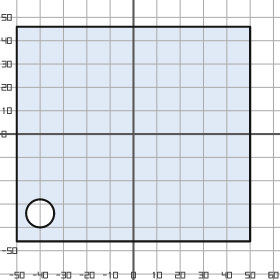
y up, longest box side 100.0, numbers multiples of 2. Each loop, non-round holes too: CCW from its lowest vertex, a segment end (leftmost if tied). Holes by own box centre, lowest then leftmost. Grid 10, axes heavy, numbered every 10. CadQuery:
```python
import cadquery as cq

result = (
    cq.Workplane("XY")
    .moveTo(-50.0, -46.0)
    .lineTo(50.0, -46.0)
    .lineTo(50.0, 46.0)
    .lineTo(-50.0, 46.0)
    .close()
    .moveTo(-40.0, -34.0)
    .circle(6.0)
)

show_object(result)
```